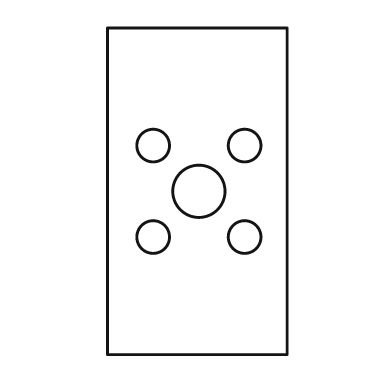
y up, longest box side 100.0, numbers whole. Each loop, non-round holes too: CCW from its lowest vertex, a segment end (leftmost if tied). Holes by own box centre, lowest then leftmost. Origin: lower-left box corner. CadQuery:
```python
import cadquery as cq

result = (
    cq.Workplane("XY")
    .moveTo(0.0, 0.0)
    .lineTo(55.0, 0.0)
    .lineTo(55.0, 100.0)
    .lineTo(0.0, 100.0)
    .close()
    .moveTo(14.0, 36.0)
    .circle(5.0)
    .moveTo(42.0, 36.0)
    .circle(5.0)
    .moveTo(28.0, 50.0)
    .circle(8.0)
    .moveTo(14.0, 64.0)
    .circle(5.0)
    .moveTo(42.0, 64.0)
    .circle(5.0)
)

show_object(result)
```